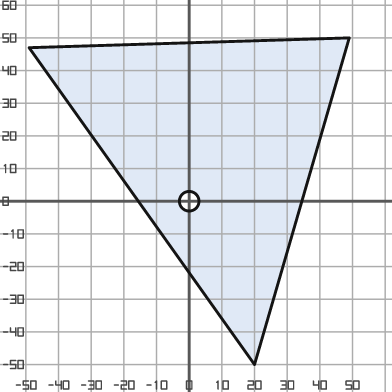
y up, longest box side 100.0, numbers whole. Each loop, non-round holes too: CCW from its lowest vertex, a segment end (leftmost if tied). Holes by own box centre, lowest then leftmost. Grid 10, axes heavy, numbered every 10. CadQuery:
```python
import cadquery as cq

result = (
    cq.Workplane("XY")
    .moveTo(20.0, -50.0)
    .lineTo(49.0, 50.0)
    .lineTo(-49.0, 47.0)
    .close()
    .moveTo(0.0, 0.0)
    .circle(3.0)
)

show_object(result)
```